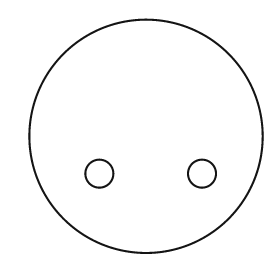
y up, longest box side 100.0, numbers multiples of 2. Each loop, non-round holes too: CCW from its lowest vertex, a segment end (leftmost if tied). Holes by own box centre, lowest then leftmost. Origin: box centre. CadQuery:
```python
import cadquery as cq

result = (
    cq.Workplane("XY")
    .moveTo(0.0, 0.0)
    .circle(50.0)
    .moveTo(-20.0, -16.0)
    .circle(6.0)
    .moveTo(24.0, -16.0)
    .circle(6.0)
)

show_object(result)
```